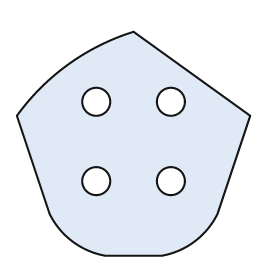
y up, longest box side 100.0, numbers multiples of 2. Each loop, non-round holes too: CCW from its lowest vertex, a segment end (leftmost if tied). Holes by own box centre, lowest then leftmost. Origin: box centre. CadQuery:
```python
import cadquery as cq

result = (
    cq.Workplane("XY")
    .moveTo(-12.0, -48.0)
    .lineTo(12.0, -48.0)
    .threePointArc((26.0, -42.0), (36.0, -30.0))
    .lineTo(50.0, 12.0)
    .lineTo(0.0, 48.0)
    .threePointArc((-28.0, 34.0), (-50.0, 12.0))
    .lineTo(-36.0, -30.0)
    .threePointArc((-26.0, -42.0), (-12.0, -48.0))
    .close()
    .moveTo(-16.0, -16.0)
    .circle(6.0)
    .moveTo(16.0, -16.0)
    .circle(6.0)
    .moveTo(-16.0, 18.0)
    .circle(6.0)
    .moveTo(16.0, 18.0)
    .circle(6.0)
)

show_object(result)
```